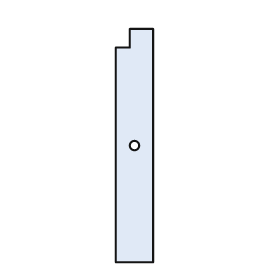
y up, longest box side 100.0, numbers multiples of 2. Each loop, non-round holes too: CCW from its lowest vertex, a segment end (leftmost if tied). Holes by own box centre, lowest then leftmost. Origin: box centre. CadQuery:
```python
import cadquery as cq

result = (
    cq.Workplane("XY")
    .moveTo(-8.0, -50.0)
    .lineTo(8.0, -50.0)
    .lineTo(8.0, 50.0)
    .lineTo(-2.0, 50.0)
    .lineTo(-2.0, 42.0)
    .lineTo(-8.0, 42.0)
    .close()
    .moveTo(0.0, 0.0)
    .circle(2.0)
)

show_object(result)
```